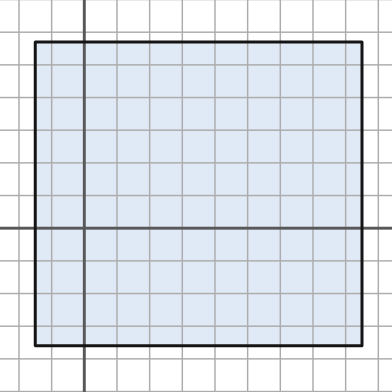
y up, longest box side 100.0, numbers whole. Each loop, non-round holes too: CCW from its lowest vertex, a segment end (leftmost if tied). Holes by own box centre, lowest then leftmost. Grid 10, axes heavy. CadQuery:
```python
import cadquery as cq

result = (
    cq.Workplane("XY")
    .moveTo(-15.0, -36.0)
    .lineTo(85.0, -36.0)
    .lineTo(85.0, 57.0)
    .lineTo(-15.0, 57.0)
    .close()
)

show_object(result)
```